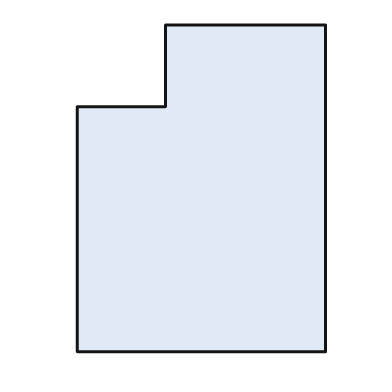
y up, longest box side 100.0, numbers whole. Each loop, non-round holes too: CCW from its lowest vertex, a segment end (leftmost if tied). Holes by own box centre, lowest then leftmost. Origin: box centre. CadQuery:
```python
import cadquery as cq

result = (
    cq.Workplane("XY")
    .moveTo(-38.0, -50.0)
    .lineTo(38.0, -50.0)
    .lineTo(38.0, 50.0)
    .lineTo(-11.0, 50.0)
    .lineTo(-11.0, 25.0)
    .lineTo(-38.0, 25.0)
    .close()
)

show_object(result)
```